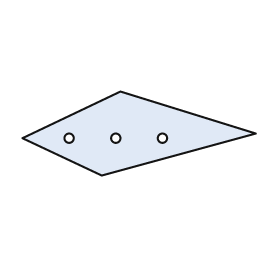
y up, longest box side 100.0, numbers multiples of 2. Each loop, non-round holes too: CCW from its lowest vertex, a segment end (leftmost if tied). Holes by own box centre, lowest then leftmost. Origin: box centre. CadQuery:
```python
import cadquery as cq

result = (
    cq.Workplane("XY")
    .moveTo(-16.0, -18.0)
    .lineTo(50.0, 0.0)
    .lineTo(-8.0, 18.0)
    .lineTo(-50.0, -2.0)
    .close()
    .moveTo(-30.0, -2.0)
    .circle(2.0)
    .moveTo(-10.0, -2.0)
    .circle(2.0)
    .moveTo(10.0, -2.0)
    .circle(2.0)
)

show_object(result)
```